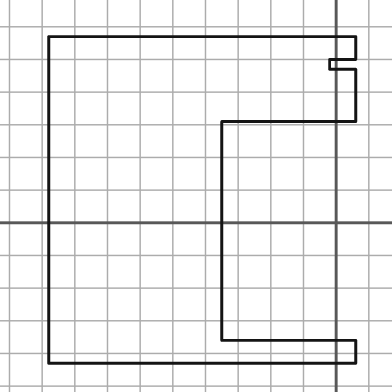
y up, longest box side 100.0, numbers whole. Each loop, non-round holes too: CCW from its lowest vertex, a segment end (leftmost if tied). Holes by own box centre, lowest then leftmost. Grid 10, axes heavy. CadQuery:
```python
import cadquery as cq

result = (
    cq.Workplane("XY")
    .moveTo(-88.0, -43.0)
    .lineTo(6.0, -43.0)
    .lineTo(6.0, -36.0)
    .lineTo(-35.0, -36.0)
    .lineTo(-35.0, 31.0)
    .lineTo(6.0, 31.0)
    .lineTo(6.0, 47.0)
    .lineTo(-2.0, 47.0)
    .lineTo(-2.0, 50.0)
    .lineTo(6.0, 50.0)
    .lineTo(6.0, 57.0)
    .lineTo(-88.0, 57.0)
    .close()
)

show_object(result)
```